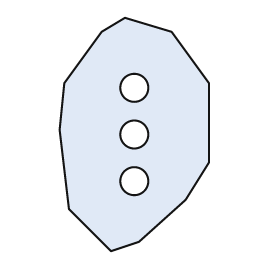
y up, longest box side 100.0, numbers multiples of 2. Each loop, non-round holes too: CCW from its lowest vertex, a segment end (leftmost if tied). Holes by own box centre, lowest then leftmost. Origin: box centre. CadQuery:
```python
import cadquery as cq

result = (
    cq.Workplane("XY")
    .moveTo(-10.0, -50.0)
    .lineTo(2.0, -46.0)
    .lineTo(22.0, -28.0)
    .lineTo(32.0, -12.0)
    .lineTo(32.0, 22.0)
    .lineTo(16.0, 44.0)
    .lineTo(-4.0, 50.0)
    .lineTo(-14.0, 44.0)
    .lineTo(-30.0, 22.0)
    .lineTo(-32.0, 2.0)
    .lineTo(-28.0, -32.0)
    .close()
    .moveTo(0.0, -20.0)
    .circle(6.0)
    .moveTo(0.0, 0.0)
    .circle(6.0)
    .moveTo(0.0, 20.0)
    .circle(6.0)
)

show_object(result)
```